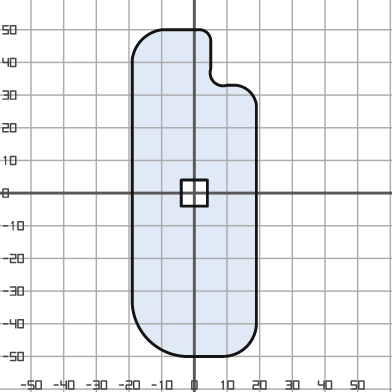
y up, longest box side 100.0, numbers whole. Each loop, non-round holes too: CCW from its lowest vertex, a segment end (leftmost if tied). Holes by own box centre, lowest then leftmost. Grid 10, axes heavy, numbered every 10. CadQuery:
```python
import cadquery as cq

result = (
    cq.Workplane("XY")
    .moveTo(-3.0, -50.0)
    .lineTo(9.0, -50.0)
    .threePointArc((16.0, -47.0), (19.0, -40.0))
    .lineTo(19.0, 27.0)
    .threePointArc((17.0, 31.0), (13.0, 33.0))
    .lineTo(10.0, 33.0)
    .threePointArc((6.0, 34.0), (5.0, 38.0))
    .lineTo(5.0, 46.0)
    .threePointArc((4.0, 49.0), (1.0, 50.0))
    .lineTo(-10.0, 50.0)
    .threePointArc((-16.0, 47.0), (-19.0, 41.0))
    .lineTo(-19.0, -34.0)
    .threePointArc((-14.0, -45.0), (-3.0, -50.0))
    .close()
    .moveTo(-4.0, -4.0)
    .lineTo(4.0, -4.0)
    .lineTo(4.0, 4.0)
    .lineTo(-4.0, 4.0)
    .close()
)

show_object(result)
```